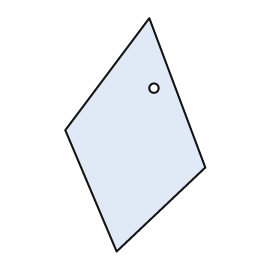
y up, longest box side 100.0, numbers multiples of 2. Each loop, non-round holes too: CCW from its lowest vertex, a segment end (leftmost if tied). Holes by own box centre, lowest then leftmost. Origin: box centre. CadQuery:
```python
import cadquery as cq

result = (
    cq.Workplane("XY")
    .moveTo(-8.0, -50.0)
    .lineTo(30.0, -14.0)
    .lineTo(6.0, 50.0)
    .lineTo(-30.0, 2.0)
    .close()
    .moveTo(8.0, 20.0)
    .circle(2.0)
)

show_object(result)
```